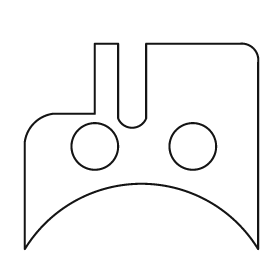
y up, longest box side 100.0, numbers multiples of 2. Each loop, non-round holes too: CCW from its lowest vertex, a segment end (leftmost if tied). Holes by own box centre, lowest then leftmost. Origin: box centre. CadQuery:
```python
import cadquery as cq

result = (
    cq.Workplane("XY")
    .moveTo(-50.0, -44.0)
    .threePointArc((0.0, -16.0), (50.0, -44.0))
    .lineTo(50.0, 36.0)
    .threePointArc((48.0, 42.0), (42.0, 44.0))
    .lineTo(2.0, 44.0)
    .lineTo(2.0, 12.0)
    .threePointArc((-4.0, 8.0), (-10.0, 12.0))
    .lineTo(-10.0, 44.0)
    .lineTo(-20.0, 44.0)
    .lineTo(-20.0, 14.0)
    .lineTo(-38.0, 14.0)
    .threePointArc((-46.0, 10.0), (-50.0, 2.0))
    .close()
    .moveTo(-20.0, 0.0)
    .circle(10.0)
    .moveTo(22.0, 0.0)
    .circle(10.0)
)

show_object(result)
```